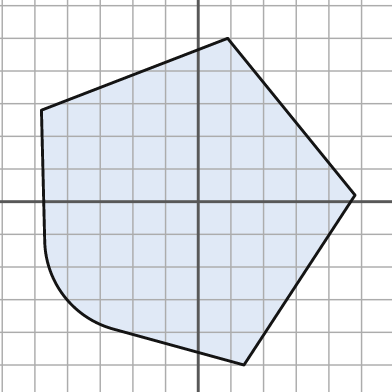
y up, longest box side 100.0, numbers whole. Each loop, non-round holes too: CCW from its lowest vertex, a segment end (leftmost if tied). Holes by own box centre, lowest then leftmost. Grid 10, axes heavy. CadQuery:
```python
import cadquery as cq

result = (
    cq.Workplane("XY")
    .moveTo(14.0, -50.0)
    .lineTo(48.0, 2.0)
    .lineTo(9.0, 50.0)
    .lineTo(-48.0, 28.0)
    .lineTo(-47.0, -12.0)
    .threePointArc((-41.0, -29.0), (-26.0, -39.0))
    .close()
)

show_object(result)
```